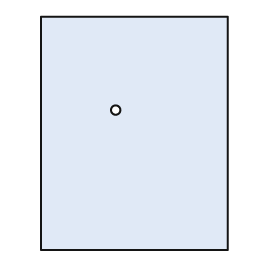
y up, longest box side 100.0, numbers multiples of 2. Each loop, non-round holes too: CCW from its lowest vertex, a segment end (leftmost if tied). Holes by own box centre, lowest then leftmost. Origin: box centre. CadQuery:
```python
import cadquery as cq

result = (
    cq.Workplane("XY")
    .moveTo(-40.0, -50.0)
    .lineTo(40.0, -50.0)
    .lineTo(40.0, 50.0)
    .lineTo(-40.0, 50.0)
    .close()
    .moveTo(-8.0, 10.0)
    .circle(2.0)
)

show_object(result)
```